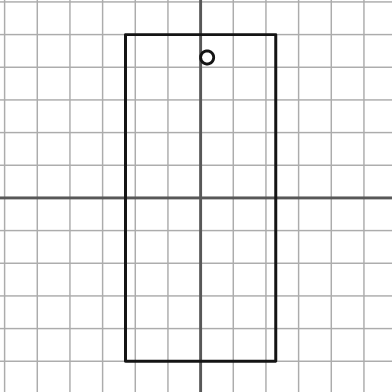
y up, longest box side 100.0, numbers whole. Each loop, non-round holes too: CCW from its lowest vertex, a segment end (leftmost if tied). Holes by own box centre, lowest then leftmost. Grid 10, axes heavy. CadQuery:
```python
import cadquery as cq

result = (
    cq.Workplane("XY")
    .moveTo(-23.0, -50.0)
    .lineTo(23.0, -50.0)
    .lineTo(23.0, 50.0)
    .lineTo(-23.0, 50.0)
    .close()
    .moveTo(2.0, 43.0)
    .circle(2.0)
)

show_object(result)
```